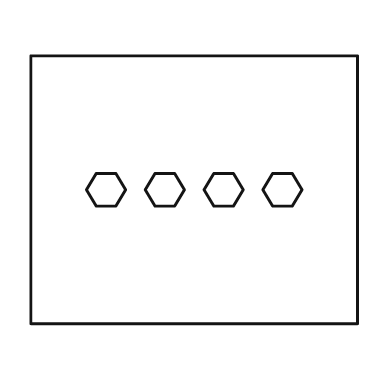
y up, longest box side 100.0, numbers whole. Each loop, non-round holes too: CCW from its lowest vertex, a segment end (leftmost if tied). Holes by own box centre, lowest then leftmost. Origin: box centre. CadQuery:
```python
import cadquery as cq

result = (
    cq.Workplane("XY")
    .moveTo(-50.0, -41.0)
    .lineTo(50.0, -41.0)
    .lineTo(50.0, 41.0)
    .lineTo(-50.0, 41.0)
    .close()
    .moveTo(-30.0, -5.0)
    .lineTo(-24.0, -5.0)
    .lineTo(-21.0, 0.0)
    .lineTo(-24.0, 5.0)
    .lineTo(-30.0, 5.0)
    .lineTo(-33.0, 0.0)
    .close()
    .moveTo(-12.0, -5.0)
    .lineTo(-6.0, -5.0)
    .lineTo(-3.0, 0.0)
    .lineTo(-6.0, 5.0)
    .lineTo(-12.0, 5.0)
    .lineTo(-15.0, 0.0)
    .close()
    .moveTo(6.0, -5.0)
    .lineTo(12.0, -5.0)
    .lineTo(15.0, 0.0)
    .lineTo(12.0, 5.0)
    .lineTo(6.0, 5.0)
    .lineTo(3.0, 0.0)
    .close()
    .moveTo(24.0, -5.0)
    .lineTo(30.0, -5.0)
    .lineTo(33.0, 0.0)
    .lineTo(30.0, 5.0)
    .lineTo(24.0, 5.0)
    .lineTo(21.0, 0.0)
    .close()
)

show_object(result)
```